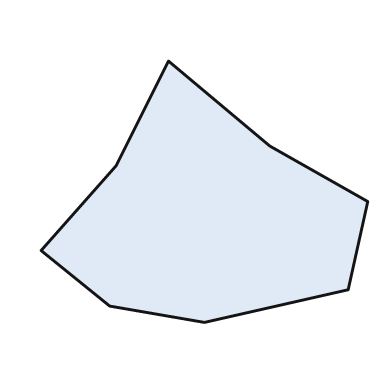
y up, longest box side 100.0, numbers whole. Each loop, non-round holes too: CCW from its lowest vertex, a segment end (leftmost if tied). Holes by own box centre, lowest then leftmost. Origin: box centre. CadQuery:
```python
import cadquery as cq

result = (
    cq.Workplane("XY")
    .moveTo(0.0, -40.0)
    .lineTo(44.0, -30.0)
    .lineTo(50.0, -3.0)
    .lineTo(20.0, 14.0)
    .lineTo(-11.0, 40.0)
    .lineTo(-27.0, 8.0)
    .lineTo(-50.0, -18.0)
    .lineTo(-29.0, -35.0)
    .close()
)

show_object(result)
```